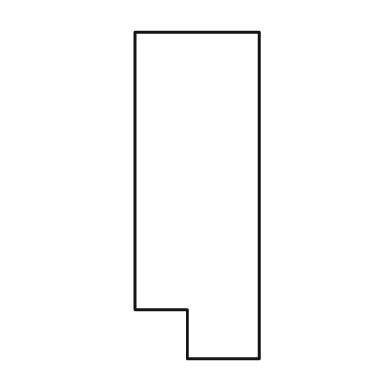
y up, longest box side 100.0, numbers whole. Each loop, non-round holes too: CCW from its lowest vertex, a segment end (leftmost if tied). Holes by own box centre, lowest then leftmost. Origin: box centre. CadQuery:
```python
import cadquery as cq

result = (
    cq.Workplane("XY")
    .moveTo(-3.0, -50.0)
    .lineTo(19.0, -50.0)
    .lineTo(19.0, 50.0)
    .lineTo(-19.0, 50.0)
    .lineTo(-19.0, -35.0)
    .lineTo(-3.0, -35.0)
    .close()
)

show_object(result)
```